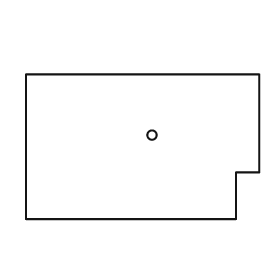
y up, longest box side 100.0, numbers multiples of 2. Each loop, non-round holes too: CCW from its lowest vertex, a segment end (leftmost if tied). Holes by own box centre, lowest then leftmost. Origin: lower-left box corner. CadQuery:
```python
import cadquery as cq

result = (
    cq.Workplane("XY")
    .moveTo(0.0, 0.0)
    .lineTo(90.0, 0.0)
    .lineTo(90.0, 20.0)
    .lineTo(100.0, 20.0)
    .lineTo(100.0, 62.0)
    .lineTo(0.0, 62.0)
    .close()
    .moveTo(54.0, 36.0)
    .circle(2.0)
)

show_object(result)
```